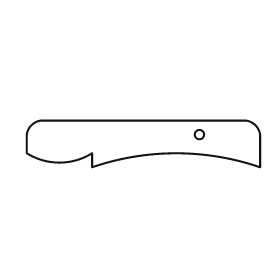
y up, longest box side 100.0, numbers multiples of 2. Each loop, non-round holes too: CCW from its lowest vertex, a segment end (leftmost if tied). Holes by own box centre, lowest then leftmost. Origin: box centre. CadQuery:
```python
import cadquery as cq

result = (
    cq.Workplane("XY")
    .moveTo(-22.0, -10.0)
    .threePointArc((14.0, -4.0), (50.0, -10.0))
    .lineTo(50.0, 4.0)
    .threePointArc((48.0, 8.0), (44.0, 10.0))
    .lineTo(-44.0, 10.0)
    .threePointArc((-48.0, 8.0), (-50.0, 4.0))
    .lineTo(-50.0, -4.0)
    .threePointArc((-36.0, -8.0), (-22.0, -4.0))
    .close()
    .moveTo(24.0, 4.0)
    .circle(2.0)
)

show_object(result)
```